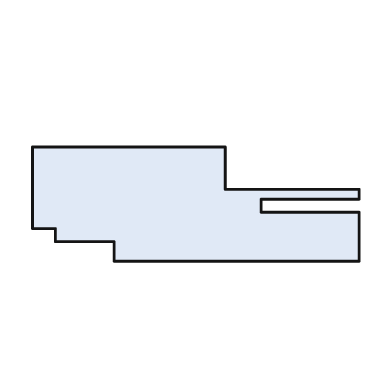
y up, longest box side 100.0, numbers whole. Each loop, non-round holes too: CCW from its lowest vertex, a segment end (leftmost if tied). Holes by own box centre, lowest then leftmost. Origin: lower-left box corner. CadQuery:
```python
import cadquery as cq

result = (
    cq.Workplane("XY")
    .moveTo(25.0, 0.0)
    .lineTo(100.0, 0.0)
    .lineTo(100.0, 15.0)
    .lineTo(70.0, 15.0)
    .lineTo(70.0, 19.0)
    .lineTo(100.0, 19.0)
    .lineTo(100.0, 22.0)
    .lineTo(59.0, 22.0)
    .lineTo(59.0, 35.0)
    .lineTo(0.0, 35.0)
    .lineTo(0.0, 10.0)
    .lineTo(7.0, 10.0)
    .lineTo(7.0, 6.0)
    .lineTo(25.0, 6.0)
    .close()
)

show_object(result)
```